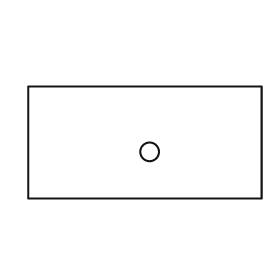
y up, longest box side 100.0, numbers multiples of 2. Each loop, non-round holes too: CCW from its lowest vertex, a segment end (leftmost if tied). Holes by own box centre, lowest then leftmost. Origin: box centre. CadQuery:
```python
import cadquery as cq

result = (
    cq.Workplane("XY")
    .moveTo(-50.0, -24.0)
    .lineTo(50.0, -24.0)
    .lineTo(50.0, 24.0)
    .lineTo(-50.0, 24.0)
    .close()
    .moveTo(2.0, -4.0)
    .circle(4.0)
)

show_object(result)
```